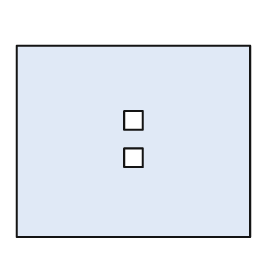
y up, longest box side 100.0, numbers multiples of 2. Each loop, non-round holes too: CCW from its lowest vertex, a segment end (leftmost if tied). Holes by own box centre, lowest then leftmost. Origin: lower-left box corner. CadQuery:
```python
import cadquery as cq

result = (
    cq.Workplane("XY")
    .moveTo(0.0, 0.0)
    .lineTo(100.0, 0.0)
    .lineTo(100.0, 82.0)
    .lineTo(0.0, 82.0)
    .close()
    .moveTo(46.0, 30.0)
    .lineTo(54.0, 30.0)
    .lineTo(54.0, 38.0)
    .lineTo(46.0, 38.0)
    .close()
    .moveTo(46.0, 46.0)
    .lineTo(54.0, 46.0)
    .lineTo(54.0, 54.0)
    .lineTo(46.0, 54.0)
    .close()
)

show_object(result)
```